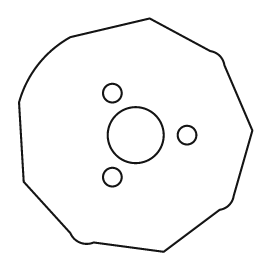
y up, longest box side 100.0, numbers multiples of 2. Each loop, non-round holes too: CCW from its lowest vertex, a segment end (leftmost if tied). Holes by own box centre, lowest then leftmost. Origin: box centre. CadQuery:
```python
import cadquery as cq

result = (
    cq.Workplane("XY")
    .moveTo(12.0, -50.0)
    .lineTo(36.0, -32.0)
    .threePointArc((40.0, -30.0), (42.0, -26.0))
    .lineTo(50.0, 2.0)
    .lineTo(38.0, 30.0)
    .threePointArc((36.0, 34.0), (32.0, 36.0))
    .lineTo(6.0, 50.0)
    .lineTo(-28.0, 42.0)
    .threePointArc((-42.0, 30.0), (-50.0, 14.0))
    .lineTo(-48.0, -20.0)
    .lineTo(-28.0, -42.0)
    .threePointArc((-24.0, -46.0), (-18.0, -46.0))
    .close()
    .moveTo(-10.0, -18.0)
    .circle(4.0)
    .moveTo(0.0, 0.0)
    .circle(12.0)
    .moveTo(22.0, 0.0)
    .circle(4.0)
    .moveTo(-10.0, 18.0)
    .circle(4.0)
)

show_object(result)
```